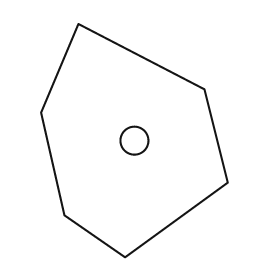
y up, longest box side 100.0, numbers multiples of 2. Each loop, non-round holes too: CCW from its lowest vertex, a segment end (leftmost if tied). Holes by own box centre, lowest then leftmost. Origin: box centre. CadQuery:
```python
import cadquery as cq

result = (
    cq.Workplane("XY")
    .moveTo(-4.0, -50.0)
    .lineTo(40.0, -18.0)
    .lineTo(30.0, 22.0)
    .lineTo(-24.0, 50.0)
    .lineTo(-40.0, 12.0)
    .lineTo(-30.0, -32.0)
    .close()
    .moveTo(0.0, 0.0)
    .circle(6.0)
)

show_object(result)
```